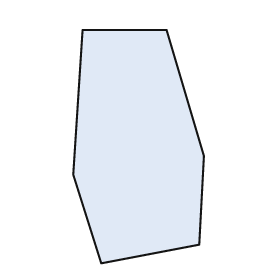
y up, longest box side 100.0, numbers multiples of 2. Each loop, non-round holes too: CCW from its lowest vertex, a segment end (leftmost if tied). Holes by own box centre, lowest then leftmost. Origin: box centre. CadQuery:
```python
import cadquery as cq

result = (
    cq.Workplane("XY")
    .moveTo(-16.0, -50.0)
    .lineTo(26.0, -42.0)
    .lineTo(28.0, -4.0)
    .lineTo(12.0, 50.0)
    .lineTo(-24.0, 50.0)
    .lineTo(-28.0, -12.0)
    .close()
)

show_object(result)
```